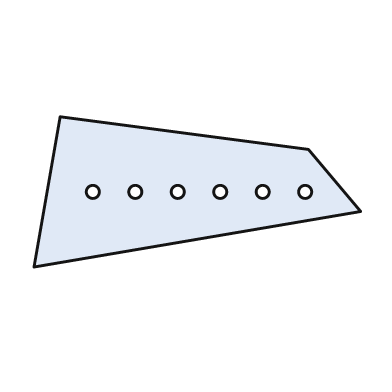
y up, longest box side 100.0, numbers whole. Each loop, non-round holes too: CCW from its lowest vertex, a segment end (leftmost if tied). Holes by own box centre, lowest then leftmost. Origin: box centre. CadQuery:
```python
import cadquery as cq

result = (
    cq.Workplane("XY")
    .moveTo(-50.0, -23.0)
    .lineTo(50.0, -6.0)
    .lineTo(34.0, 13.0)
    .lineTo(-42.0, 23.0)
    .close()
    .moveTo(-32.0, 0.0)
    .circle(2.0)
    .moveTo(-19.0, 0.0)
    .circle(2.0)
    .moveTo(-6.0, 0.0)
    .circle(2.0)
    .moveTo(7.0, 0.0)
    .circle(2.0)
    .moveTo(20.0, 0.0)
    .circle(2.0)
    .moveTo(33.0, 0.0)
    .circle(2.0)
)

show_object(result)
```